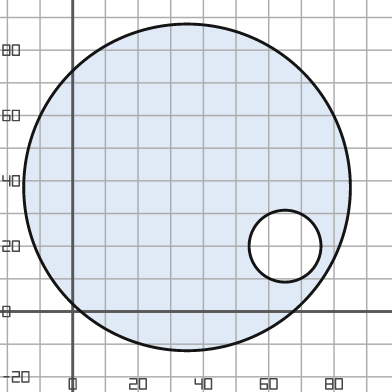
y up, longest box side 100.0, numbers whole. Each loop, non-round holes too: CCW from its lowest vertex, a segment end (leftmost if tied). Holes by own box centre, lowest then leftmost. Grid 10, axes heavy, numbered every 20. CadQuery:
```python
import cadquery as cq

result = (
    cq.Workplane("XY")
    .moveTo(35.0, 38.0)
    .circle(50.0)
    .moveTo(65.0, 20.0)
    .circle(11.0)
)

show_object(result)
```